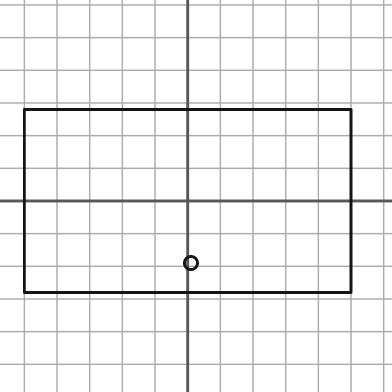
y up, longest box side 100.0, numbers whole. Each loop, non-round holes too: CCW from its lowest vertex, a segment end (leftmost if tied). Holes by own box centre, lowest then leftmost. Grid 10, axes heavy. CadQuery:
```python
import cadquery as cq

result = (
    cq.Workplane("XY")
    .moveTo(-50.0, -28.0)
    .lineTo(50.0, -28.0)
    .lineTo(50.0, 28.0)
    .lineTo(-50.0, 28.0)
    .close()
    .moveTo(1.0, -19.0)
    .circle(2.0)
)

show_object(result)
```